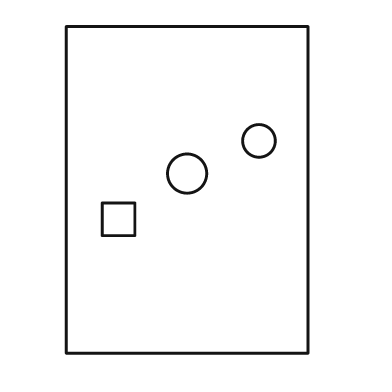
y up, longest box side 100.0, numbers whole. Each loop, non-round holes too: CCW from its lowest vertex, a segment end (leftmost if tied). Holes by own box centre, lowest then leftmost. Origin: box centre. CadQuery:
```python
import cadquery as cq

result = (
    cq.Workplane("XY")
    .moveTo(-37.0, -50.0)
    .lineTo(37.0, -50.0)
    .lineTo(37.0, 50.0)
    .lineTo(-37.0, 50.0)
    .close()
    .moveTo(-26.0, -14.0)
    .lineTo(-16.0, -14.0)
    .lineTo(-16.0, -4.0)
    .lineTo(-26.0, -4.0)
    .close()
    .moveTo(0.0, 5.0)
    .circle(6.0)
    .moveTo(22.0, 15.0)
    .circle(5.0)
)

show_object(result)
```